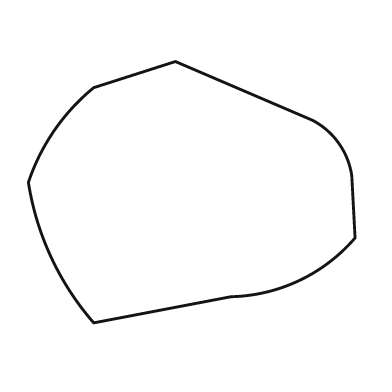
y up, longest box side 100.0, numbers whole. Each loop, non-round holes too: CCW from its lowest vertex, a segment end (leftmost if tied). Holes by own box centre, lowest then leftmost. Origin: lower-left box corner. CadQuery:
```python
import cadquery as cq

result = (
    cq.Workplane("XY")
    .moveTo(20.0, 0.0)
    .lineTo(62.0, 8.0)
    .threePointArc((83.0, 13.0), (100.0, 26.0))
    .lineTo(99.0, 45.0)
    .threePointArc((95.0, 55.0), (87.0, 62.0))
    .lineTo(45.0, 80.0)
    .lineTo(20.0, 72.0)
    .threePointArc((8.0, 59.0), (0.0, 43.0))
    .threePointArc((7.0, 20.0), (20.0, 0.0))
    .close()
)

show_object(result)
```